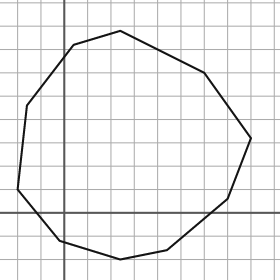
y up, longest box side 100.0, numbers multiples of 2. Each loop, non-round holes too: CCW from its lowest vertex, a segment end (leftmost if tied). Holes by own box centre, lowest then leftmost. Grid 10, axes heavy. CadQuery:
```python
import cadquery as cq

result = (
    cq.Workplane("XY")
    .moveTo(24.0, -20.0)
    .lineTo(44.0, -16.0)
    .lineTo(70.0, 6.0)
    .lineTo(80.0, 32.0)
    .lineTo(60.0, 60.0)
    .lineTo(24.0, 78.0)
    .lineTo(4.0, 72.0)
    .lineTo(-16.0, 46.0)
    .lineTo(-20.0, 10.0)
    .lineTo(-2.0, -12.0)
    .close()
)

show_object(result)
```